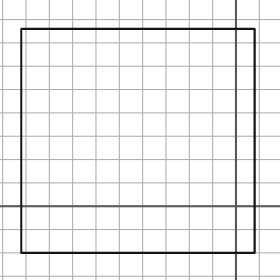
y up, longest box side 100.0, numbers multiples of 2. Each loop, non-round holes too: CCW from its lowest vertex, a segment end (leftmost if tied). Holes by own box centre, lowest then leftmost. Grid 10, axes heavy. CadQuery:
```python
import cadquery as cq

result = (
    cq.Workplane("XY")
    .moveTo(-92.0, -20.0)
    .lineTo(8.0, -20.0)
    .lineTo(8.0, 76.0)
    .lineTo(-92.0, 76.0)
    .close()
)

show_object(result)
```